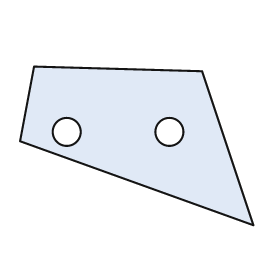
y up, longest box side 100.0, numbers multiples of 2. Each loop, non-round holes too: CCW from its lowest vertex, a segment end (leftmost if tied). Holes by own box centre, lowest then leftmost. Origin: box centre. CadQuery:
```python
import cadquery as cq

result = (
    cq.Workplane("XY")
    .moveTo(50.0, -34.0)
    .lineTo(28.0, 32.0)
    .lineTo(-44.0, 34.0)
    .lineTo(-50.0, 2.0)
    .close()
    .moveTo(-30.0, 6.0)
    .circle(6.0)
    .moveTo(14.0, 6.0)
    .circle(6.0)
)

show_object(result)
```